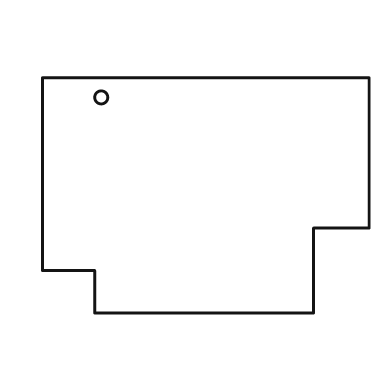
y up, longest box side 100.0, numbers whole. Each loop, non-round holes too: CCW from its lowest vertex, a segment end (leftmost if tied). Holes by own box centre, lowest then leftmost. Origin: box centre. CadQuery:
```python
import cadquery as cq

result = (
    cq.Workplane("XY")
    .moveTo(-34.0, -36.0)
    .lineTo(33.0, -36.0)
    .lineTo(33.0, -10.0)
    .lineTo(50.0, -10.0)
    .lineTo(50.0, 36.0)
    .lineTo(-50.0, 36.0)
    .lineTo(-50.0, -23.0)
    .lineTo(-34.0, -23.0)
    .close()
    .moveTo(-32.0, 30.0)
    .circle(2.0)
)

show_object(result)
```